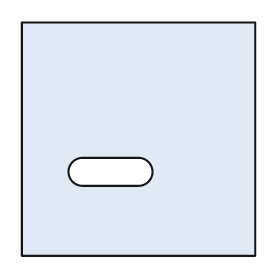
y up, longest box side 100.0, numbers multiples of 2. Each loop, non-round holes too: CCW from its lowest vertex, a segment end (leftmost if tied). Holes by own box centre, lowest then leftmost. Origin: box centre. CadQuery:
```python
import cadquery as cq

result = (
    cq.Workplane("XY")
    .moveTo(-50.0, -50.0)
    .lineTo(50.0, -50.0)
    .lineTo(50.0, 50.0)
    .lineTo(-50.0, 50.0)
    .close()
    .moveTo(-24.0, -20.0)
    .lineTo(0.0, -20.0)
    .threePointArc((6.0, -14.0), (0.0, -8.0))
    .lineTo(-24.0, -8.0)
    .threePointArc((-30.0, -14.0), (-24.0, -20.0))
    .close()
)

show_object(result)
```